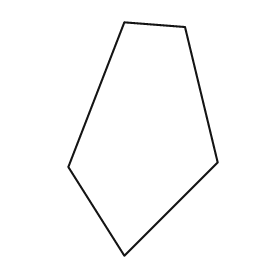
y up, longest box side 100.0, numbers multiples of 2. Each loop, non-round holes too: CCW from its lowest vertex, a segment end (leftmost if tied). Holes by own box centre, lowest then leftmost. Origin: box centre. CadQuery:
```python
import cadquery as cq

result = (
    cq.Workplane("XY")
    .moveTo(-8.0, -50.0)
    .lineTo(32.0, -10.0)
    .lineTo(18.0, 48.0)
    .lineTo(-8.0, 50.0)
    .lineTo(-32.0, -12.0)
    .close()
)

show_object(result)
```